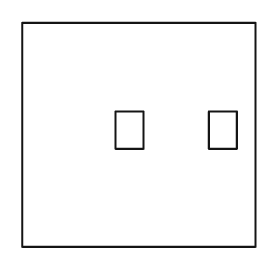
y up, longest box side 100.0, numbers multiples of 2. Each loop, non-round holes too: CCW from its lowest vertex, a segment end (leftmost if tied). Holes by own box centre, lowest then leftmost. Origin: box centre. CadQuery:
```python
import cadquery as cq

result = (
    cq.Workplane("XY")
    .moveTo(-50.0, -48.0)
    .lineTo(50.0, -48.0)
    .lineTo(50.0, 48.0)
    .lineTo(-50.0, 48.0)
    .close()
    .moveTo(-10.0, -6.0)
    .lineTo(2.0, -6.0)
    .lineTo(2.0, 10.0)
    .lineTo(-10.0, 10.0)
    .close()
    .moveTo(30.0, -6.0)
    .lineTo(42.0, -6.0)
    .lineTo(42.0, 10.0)
    .lineTo(30.0, 10.0)
    .close()
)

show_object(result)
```